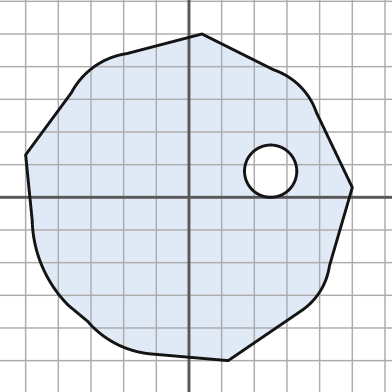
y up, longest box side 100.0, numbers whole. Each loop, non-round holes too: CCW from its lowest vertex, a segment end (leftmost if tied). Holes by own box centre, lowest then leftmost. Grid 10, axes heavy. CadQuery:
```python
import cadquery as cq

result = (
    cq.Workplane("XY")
    .moveTo(12.0, -50.0)
    .lineTo(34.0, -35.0)
    .threePointArc((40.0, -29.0), (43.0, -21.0))
    .lineTo(50.0, 3.0)
    .lineTo(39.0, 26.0)
    .threePointArc((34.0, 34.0), (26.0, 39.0))
    .lineTo(4.0, 50.0)
    .lineTo(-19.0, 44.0)
    .threePointArc((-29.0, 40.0), (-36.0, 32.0))
    .lineTo(-50.0, 13.0)
    .lineTo(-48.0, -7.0)
    .threePointArc((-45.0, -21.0), (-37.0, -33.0))
    .lineTo(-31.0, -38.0)
    .threePointArc((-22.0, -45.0), (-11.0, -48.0))
    .close()
    .moveTo(25.0, 8.0)
    .circle(8.0)
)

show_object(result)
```